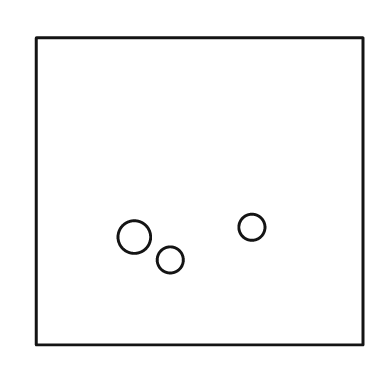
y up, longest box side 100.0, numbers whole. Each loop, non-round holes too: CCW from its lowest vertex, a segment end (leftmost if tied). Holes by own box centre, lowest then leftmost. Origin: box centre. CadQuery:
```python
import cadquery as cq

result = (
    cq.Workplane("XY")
    .moveTo(-50.0, -47.0)
    .lineTo(50.0, -47.0)
    .lineTo(50.0, 47.0)
    .lineTo(-50.0, 47.0)
    .close()
    .moveTo(-9.0, -21.0)
    .circle(4.0)
    .moveTo(-20.0, -14.0)
    .circle(5.0)
    .moveTo(16.0, -11.0)
    .circle(4.0)
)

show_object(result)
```